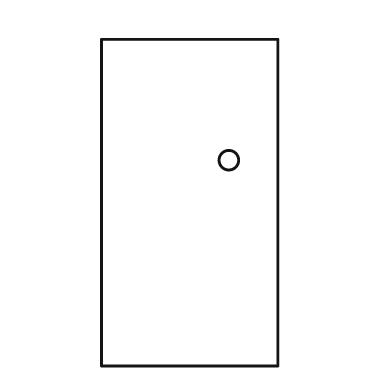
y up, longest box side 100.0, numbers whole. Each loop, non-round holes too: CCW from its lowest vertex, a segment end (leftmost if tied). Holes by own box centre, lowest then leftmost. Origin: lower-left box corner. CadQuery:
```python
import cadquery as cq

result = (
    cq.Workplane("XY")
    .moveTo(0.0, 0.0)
    .lineTo(54.0, 0.0)
    .lineTo(54.0, 100.0)
    .lineTo(0.0, 100.0)
    .close()
    .moveTo(39.0, 63.0)
    .circle(3.0)
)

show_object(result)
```